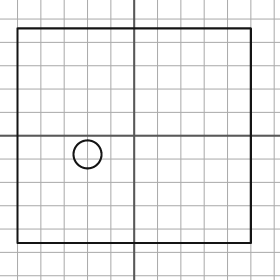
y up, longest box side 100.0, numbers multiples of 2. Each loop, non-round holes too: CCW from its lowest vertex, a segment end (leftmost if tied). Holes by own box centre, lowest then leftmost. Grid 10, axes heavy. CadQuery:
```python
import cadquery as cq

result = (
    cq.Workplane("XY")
    .moveTo(-50.0, -46.0)
    .lineTo(50.0, -46.0)
    .lineTo(50.0, 46.0)
    .lineTo(-50.0, 46.0)
    .close()
    .moveTo(-20.0, -8.0)
    .circle(6.0)
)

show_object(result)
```